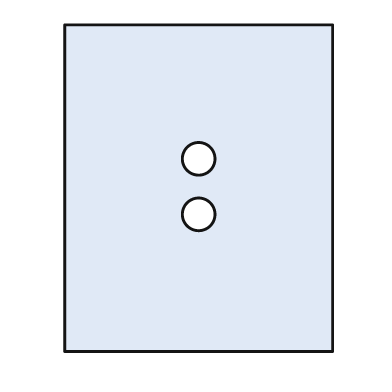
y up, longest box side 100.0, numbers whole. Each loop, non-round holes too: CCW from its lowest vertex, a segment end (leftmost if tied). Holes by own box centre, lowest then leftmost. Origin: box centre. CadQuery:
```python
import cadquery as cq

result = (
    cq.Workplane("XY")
    .moveTo(-41.0, -50.0)
    .lineTo(41.0, -50.0)
    .lineTo(41.0, 50.0)
    .lineTo(-41.0, 50.0)
    .close()
    .moveTo(0.0, -8.0)
    .circle(5.0)
    .moveTo(0.0, 9.0)
    .circle(5.0)
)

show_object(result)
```